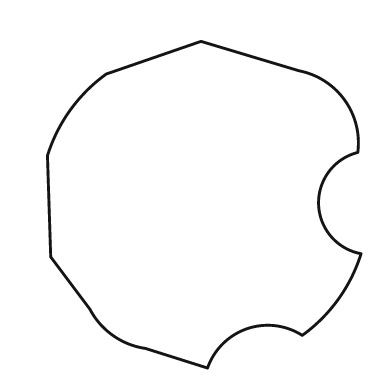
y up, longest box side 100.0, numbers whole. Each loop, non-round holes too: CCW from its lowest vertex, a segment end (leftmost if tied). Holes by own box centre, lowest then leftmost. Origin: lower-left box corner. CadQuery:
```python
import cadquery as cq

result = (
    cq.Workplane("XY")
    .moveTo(49.0, 0.0)
    .threePointArc((61.0, 12.0), (78.0, 10.0))
    .threePointArc((89.0, 21.0), (96.0, 35.0))
    .threePointArc((83.0, 50.0), (95.0, 66.0))
    .threePointArc((91.0, 82.0), (77.0, 91.0))
    .lineTo(47.0, 100.0)
    .lineTo(18.0, 90.0)
    .threePointArc((7.0, 79.0), (0.0, 65.0))
    .lineTo(1.0, 34.0)
    .lineTo(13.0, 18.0)
    .threePointArc((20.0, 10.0), (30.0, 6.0))
    .close()
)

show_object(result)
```